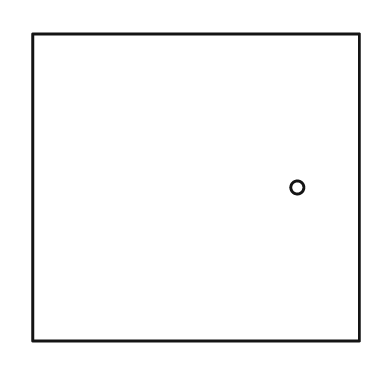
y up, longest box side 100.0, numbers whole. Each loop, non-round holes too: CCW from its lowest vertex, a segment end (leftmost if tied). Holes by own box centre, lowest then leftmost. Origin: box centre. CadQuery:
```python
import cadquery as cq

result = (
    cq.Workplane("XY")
    .moveTo(-50.0, -47.0)
    .lineTo(50.0, -47.0)
    .lineTo(50.0, 47.0)
    .lineTo(-50.0, 47.0)
    .close()
    .moveTo(31.0, 0.0)
    .circle(2.0)
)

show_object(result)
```